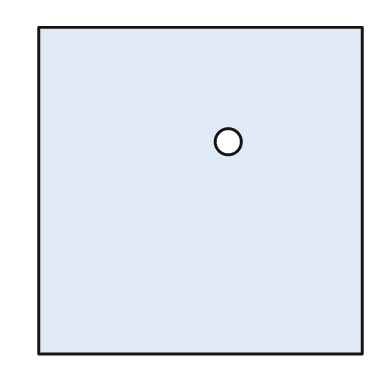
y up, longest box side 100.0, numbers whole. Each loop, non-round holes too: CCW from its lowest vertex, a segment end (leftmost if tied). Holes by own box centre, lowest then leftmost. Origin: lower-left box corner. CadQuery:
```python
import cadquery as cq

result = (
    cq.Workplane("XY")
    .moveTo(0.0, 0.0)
    .lineTo(99.0, 0.0)
    .lineTo(99.0, 100.0)
    .lineTo(0.0, 100.0)
    .close()
    .moveTo(58.0, 65.0)
    .circle(4.0)
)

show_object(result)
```